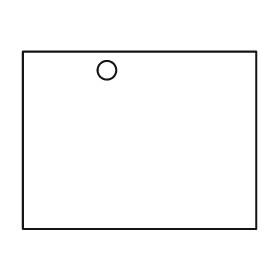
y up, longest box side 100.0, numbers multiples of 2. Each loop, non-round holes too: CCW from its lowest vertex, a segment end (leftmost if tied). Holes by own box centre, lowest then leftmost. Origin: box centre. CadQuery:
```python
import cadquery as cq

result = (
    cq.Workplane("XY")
    .moveTo(-50.0, -38.0)
    .lineTo(50.0, -38.0)
    .lineTo(50.0, 38.0)
    .lineTo(-50.0, 38.0)
    .close()
    .moveTo(-14.0, 30.0)
    .circle(4.0)
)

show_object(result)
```